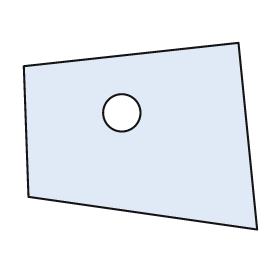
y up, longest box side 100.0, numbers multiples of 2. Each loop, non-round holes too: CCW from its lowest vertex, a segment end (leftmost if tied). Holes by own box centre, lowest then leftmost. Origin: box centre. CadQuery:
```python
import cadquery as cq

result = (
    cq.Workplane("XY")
    .moveTo(50.0, -40.0)
    .lineTo(42.0, 40.0)
    .lineTo(-50.0, 30.0)
    .lineTo(-48.0, -26.0)
    .close()
    .moveTo(-8.0, 10.0)
    .circle(8.0)
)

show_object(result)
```